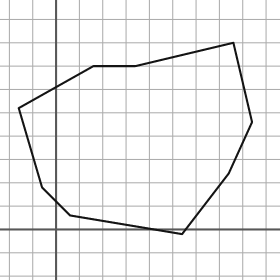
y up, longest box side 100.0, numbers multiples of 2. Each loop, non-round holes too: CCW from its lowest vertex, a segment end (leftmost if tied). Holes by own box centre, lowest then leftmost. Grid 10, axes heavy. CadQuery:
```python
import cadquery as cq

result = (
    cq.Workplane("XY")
    .moveTo(54.0, -2.0)
    .lineTo(74.0, 24.0)
    .lineTo(84.0, 46.0)
    .lineTo(76.0, 80.0)
    .lineTo(34.0, 70.0)
    .lineTo(16.0, 70.0)
    .lineTo(-16.0, 52.0)
    .lineTo(-6.0, 18.0)
    .lineTo(6.0, 6.0)
    .close()
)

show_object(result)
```